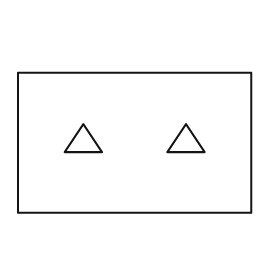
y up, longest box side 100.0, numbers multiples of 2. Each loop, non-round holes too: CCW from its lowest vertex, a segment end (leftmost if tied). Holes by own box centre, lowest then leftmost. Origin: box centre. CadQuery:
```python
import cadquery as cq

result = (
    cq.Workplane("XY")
    .moveTo(-50.0, -30.0)
    .lineTo(50.0, -30.0)
    .lineTo(50.0, 30.0)
    .lineTo(-50.0, 30.0)
    .close()
    .moveTo(-30.0, -4.0)
    .lineTo(-14.0, -4.0)
    .lineTo(-22.0, 8.0)
    .close()
    .moveTo(14.0, -4.0)
    .lineTo(30.0, -4.0)
    .lineTo(22.0, 8.0)
    .close()
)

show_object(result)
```